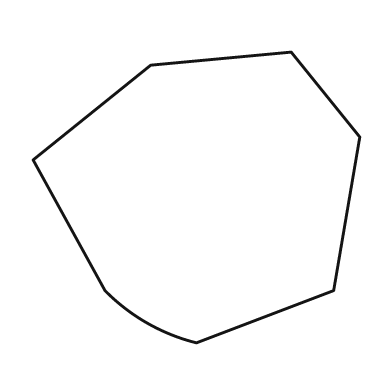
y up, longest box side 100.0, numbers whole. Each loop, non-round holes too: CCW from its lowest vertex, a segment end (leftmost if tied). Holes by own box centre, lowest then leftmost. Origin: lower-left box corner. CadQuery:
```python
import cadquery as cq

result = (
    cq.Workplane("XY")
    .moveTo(50.0, 0.0)
    .lineTo(92.0, 16.0)
    .lineTo(100.0, 63.0)
    .lineTo(79.0, 89.0)
    .lineTo(36.0, 85.0)
    .lineTo(0.0, 56.0)
    .lineTo(22.0, 16.0)
    .threePointArc((35.0, 6.0), (50.0, 0.0))
    .close()
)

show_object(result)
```